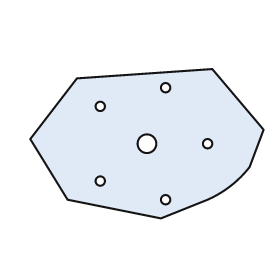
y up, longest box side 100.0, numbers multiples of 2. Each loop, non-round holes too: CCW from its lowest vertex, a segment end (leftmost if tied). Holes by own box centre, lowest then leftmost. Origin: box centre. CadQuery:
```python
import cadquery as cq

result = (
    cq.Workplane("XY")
    .moveTo(6.0, -32.0)
    .lineTo(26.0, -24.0)
    .threePointArc((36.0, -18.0), (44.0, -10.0))
    .lineTo(50.0, 6.0)
    .lineTo(28.0, 32.0)
    .lineTo(-30.0, 28.0)
    .lineTo(-50.0, 2.0)
    .lineTo(-34.0, -24.0)
    .close()
    .moveTo(8.0, -24.0)
    .circle(2.0)
    .moveTo(-20.0, -16.0)
    .circle(2.0)
    .moveTo(0.0, 0.0)
    .circle(4.0)
    .moveTo(26.0, 0.0)
    .circle(2.0)
    .moveTo(-20.0, 16.0)
    .circle(2.0)
    .moveTo(8.0, 24.0)
    .circle(2.0)
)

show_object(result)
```